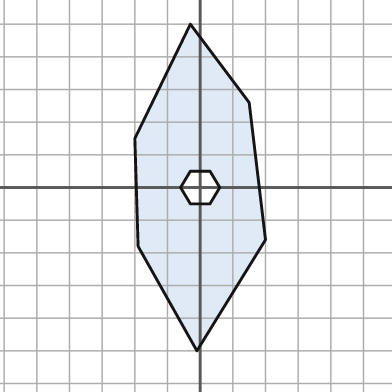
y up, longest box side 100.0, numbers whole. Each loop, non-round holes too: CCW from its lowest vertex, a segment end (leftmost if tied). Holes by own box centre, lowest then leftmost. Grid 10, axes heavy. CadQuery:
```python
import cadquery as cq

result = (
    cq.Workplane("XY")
    .moveTo(-1.0, -50.0)
    .lineTo(20.0, -16.0)
    .lineTo(15.0, 26.0)
    .lineTo(-3.0, 50.0)
    .lineTo(-20.0, 15.0)
    .lineTo(-19.0, -18.0)
    .close()
    .moveTo(-3.0, -5.0)
    .lineTo(3.0, -5.0)
    .lineTo(6.0, 0.0)
    .lineTo(3.0, 5.0)
    .lineTo(-3.0, 5.0)
    .lineTo(-6.0, 0.0)
    .close()
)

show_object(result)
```